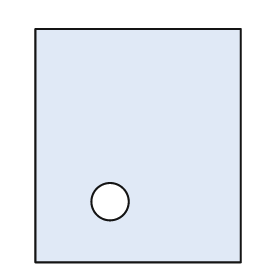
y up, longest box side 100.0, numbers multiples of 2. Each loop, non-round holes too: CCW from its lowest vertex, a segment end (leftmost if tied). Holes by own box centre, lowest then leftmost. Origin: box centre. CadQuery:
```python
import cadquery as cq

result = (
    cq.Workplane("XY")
    .moveTo(-44.0, -50.0)
    .lineTo(44.0, -50.0)
    .lineTo(44.0, 50.0)
    .lineTo(-44.0, 50.0)
    .close()
    .moveTo(-12.0, -24.0)
    .circle(8.0)
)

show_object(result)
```